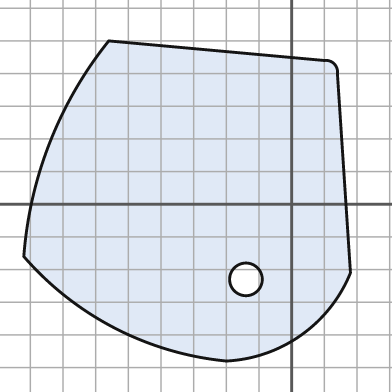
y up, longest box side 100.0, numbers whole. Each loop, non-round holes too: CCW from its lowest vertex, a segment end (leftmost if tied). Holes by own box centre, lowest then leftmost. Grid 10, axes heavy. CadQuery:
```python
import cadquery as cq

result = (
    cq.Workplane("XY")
    .moveTo(-20.0, -48.0)
    .threePointArc((3.0, -40.0), (18.0, -21.0))
    .lineTo(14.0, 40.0)
    .threePointArc((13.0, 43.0), (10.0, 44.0))
    .lineTo(-56.0, 50.0)
    .threePointArc((-74.0, 19.0), (-82.0, -16.0))
    .threePointArc((-54.0, -38.0), (-20.0, -48.0))
    .close()
    .moveTo(-14.0, -23.0)
    .circle(5.0)
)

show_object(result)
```